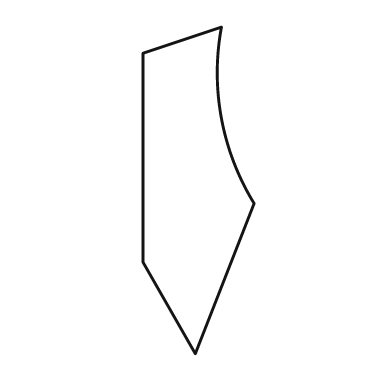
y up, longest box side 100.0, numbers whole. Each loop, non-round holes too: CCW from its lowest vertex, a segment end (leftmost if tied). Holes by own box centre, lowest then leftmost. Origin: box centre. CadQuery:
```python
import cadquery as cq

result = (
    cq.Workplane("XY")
    .moveTo(-1.0, -50.0)
    .lineTo(17.0, -4.0)
    .threePointArc((7.0, 22.0), (7.0, 50.0))
    .lineTo(-17.0, 42.0)
    .lineTo(-17.0, -22.0)
    .close()
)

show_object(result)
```